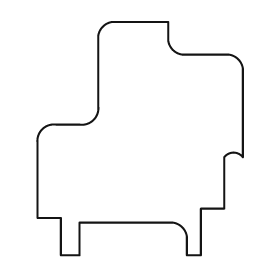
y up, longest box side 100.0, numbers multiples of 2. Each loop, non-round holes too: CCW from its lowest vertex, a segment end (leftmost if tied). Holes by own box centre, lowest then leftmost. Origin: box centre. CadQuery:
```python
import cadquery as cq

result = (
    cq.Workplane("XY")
    .moveTo(-34.0, -50.0)
    .lineTo(-26.0, -50.0)
    .lineTo(-26.0, -36.0)
    .lineTo(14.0, -36.0)
    .threePointArc((18.0, -38.0), (20.0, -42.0))
    .lineTo(20.0, -50.0)
    .lineTo(26.0, -50.0)
    .lineTo(26.0, -30.0)
    .lineTo(36.0, -30.0)
    .lineTo(36.0, -8.0)
    .threePointArc((40.0, -6.0), (44.0, -8.0))
    .lineTo(44.0, 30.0)
    .threePointArc((42.0, 34.0), (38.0, 36.0))
    .lineTo(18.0, 36.0)
    .threePointArc((14.0, 38.0), (12.0, 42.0))
    .lineTo(12.0, 50.0)
    .lineTo(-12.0, 50.0)
    .threePointArc((-16.0, 48.0), (-18.0, 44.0))
    .lineTo(-18.0, 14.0)
    .threePointArc((-20.0, 8.0), (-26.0, 6.0))
    .lineTo(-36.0, 6.0)
    .threePointArc((-42.0, 4.0), (-44.0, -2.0))
    .lineTo(-44.0, -34.0)
    .lineTo(-34.0, -34.0)
    .close()
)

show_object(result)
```